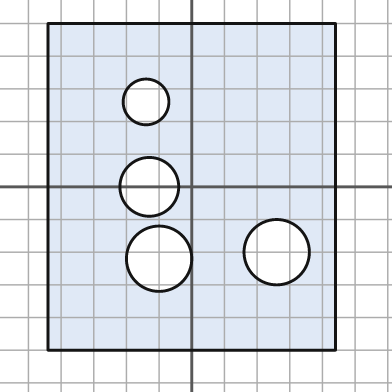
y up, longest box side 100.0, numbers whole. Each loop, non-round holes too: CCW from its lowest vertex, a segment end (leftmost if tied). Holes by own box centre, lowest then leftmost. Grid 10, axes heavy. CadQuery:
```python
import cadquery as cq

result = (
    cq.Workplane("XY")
    .moveTo(-44.0, -50.0)
    .lineTo(44.0, -50.0)
    .lineTo(44.0, 50.0)
    .lineTo(-44.0, 50.0)
    .close()
    .moveTo(-10.0, -22.0)
    .circle(10.0)
    .moveTo(26.0, -20.0)
    .circle(10.0)
    .moveTo(-13.0, 0.0)
    .circle(9.0)
    .moveTo(-14.0, 26.0)
    .circle(7.0)
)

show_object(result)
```